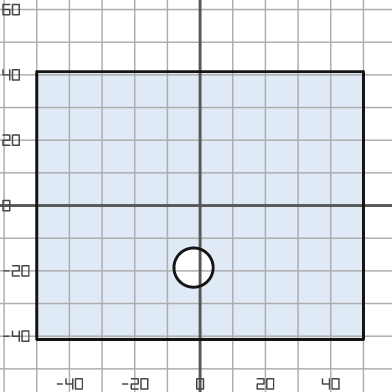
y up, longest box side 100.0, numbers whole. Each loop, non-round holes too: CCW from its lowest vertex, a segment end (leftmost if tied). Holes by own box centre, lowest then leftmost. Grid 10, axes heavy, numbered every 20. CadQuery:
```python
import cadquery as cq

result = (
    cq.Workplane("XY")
    .moveTo(-50.0, -41.0)
    .lineTo(50.0, -41.0)
    .lineTo(50.0, 41.0)
    .lineTo(-50.0, 41.0)
    .close()
    .moveTo(-2.0, -19.0)
    .circle(6.0)
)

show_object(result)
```